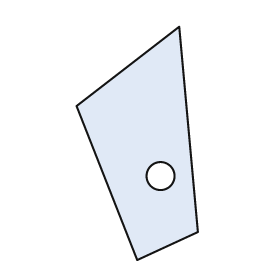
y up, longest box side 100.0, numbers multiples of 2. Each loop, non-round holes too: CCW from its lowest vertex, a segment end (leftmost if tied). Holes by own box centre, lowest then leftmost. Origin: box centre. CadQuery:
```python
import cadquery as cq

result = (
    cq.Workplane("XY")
    .moveTo(0.0, -50.0)
    .lineTo(26.0, -38.0)
    .lineTo(18.0, 50.0)
    .lineTo(-26.0, 16.0)
    .close()
    .moveTo(10.0, -14.0)
    .circle(6.0)
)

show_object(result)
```